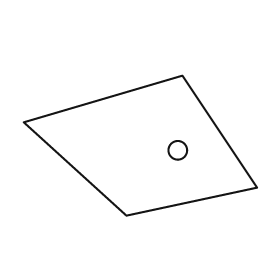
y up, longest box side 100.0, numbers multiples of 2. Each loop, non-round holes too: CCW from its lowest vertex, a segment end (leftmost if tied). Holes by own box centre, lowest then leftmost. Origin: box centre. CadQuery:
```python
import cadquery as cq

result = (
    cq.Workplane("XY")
    .moveTo(-6.0, -30.0)
    .lineTo(50.0, -18.0)
    .lineTo(18.0, 30.0)
    .lineTo(-50.0, 10.0)
    .close()
    .moveTo(16.0, -2.0)
    .circle(4.0)
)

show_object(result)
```